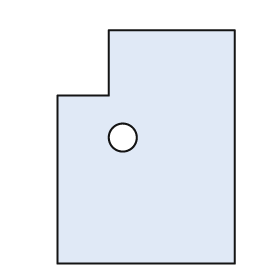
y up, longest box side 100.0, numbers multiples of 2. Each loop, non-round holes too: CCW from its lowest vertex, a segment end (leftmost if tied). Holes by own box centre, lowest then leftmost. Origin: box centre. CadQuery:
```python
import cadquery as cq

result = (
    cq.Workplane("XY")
    .moveTo(-38.0, -50.0)
    .lineTo(38.0, -50.0)
    .lineTo(38.0, 50.0)
    .lineTo(-16.0, 50.0)
    .lineTo(-16.0, 22.0)
    .lineTo(-38.0, 22.0)
    .close()
    .moveTo(-10.0, 4.0)
    .circle(6.0)
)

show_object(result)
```